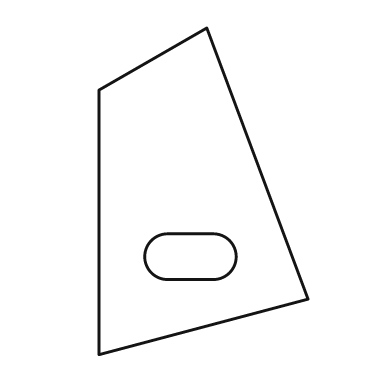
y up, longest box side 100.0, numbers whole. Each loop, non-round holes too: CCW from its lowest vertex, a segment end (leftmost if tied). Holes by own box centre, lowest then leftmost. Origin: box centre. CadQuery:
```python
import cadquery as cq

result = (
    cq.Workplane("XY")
    .moveTo(-32.0, -50.0)
    .lineTo(32.0, -33.0)
    .lineTo(1.0, 50.0)
    .lineTo(-32.0, 31.0)
    .close()
    .moveTo(-11.0, -27.0)
    .lineTo(3.0, -27.0)
    .threePointArc((10.0, -20.0), (3.0, -13.0))
    .lineTo(-11.0, -13.0)
    .threePointArc((-18.0, -20.0), (-11.0, -27.0))
    .close()
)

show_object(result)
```